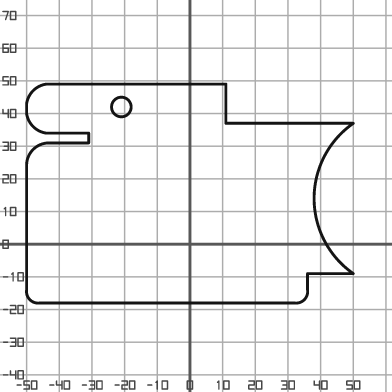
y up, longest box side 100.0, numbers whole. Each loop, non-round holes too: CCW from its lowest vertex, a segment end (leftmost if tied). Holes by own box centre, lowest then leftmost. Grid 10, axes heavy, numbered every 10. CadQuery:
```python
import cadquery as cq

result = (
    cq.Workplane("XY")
    .moveTo(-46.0, -18.0)
    .lineTo(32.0, -18.0)
    .threePointArc((35.0, -17.0), (36.0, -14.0))
    .lineTo(36.0, -9.0)
    .lineTo(50.0, -9.0)
    .threePointArc((38.0, 14.0), (50.0, 37.0))
    .lineTo(11.0, 37.0)
    .lineTo(11.0, 49.0)
    .lineTo(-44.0, 49.0)
    .threePointArc((-48.0, 47.0), (-50.0, 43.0))
    .lineTo(-50.0, 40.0)
    .threePointArc((-48.0, 36.0), (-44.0, 34.0))
    .lineTo(-31.0, 34.0)
    .lineTo(-31.0, 31.0)
    .lineTo(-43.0, 31.0)
    .threePointArc((-48.0, 29.0), (-50.0, 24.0))
    .lineTo(-50.0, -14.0)
    .threePointArc((-49.0, -17.0), (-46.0, -18.0))
    .close()
    .moveTo(-21.0, 42.0)
    .circle(3.0)
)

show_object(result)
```